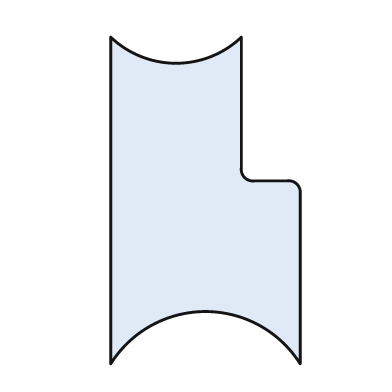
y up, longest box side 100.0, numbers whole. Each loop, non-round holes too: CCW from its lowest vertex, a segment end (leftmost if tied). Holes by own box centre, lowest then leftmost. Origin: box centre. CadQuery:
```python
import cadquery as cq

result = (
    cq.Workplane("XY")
    .moveTo(-29.0, -50.0)
    .threePointArc((0.0, -34.0), (29.0, -50.0))
    .lineTo(29.0, 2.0)
    .threePointArc((28.0, 5.0), (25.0, 6.0))
    .lineTo(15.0, 6.0)
    .threePointArc((12.0, 7.0), (11.0, 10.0))
    .lineTo(11.0, 50.0)
    .threePointArc((-9.0, 42.0), (-29.0, 50.0))
    .close()
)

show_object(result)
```